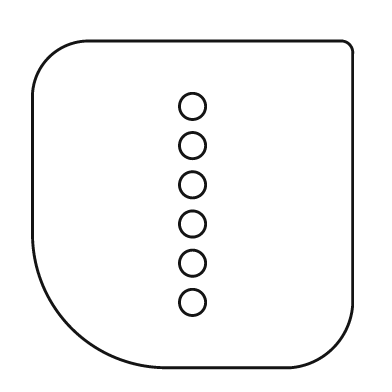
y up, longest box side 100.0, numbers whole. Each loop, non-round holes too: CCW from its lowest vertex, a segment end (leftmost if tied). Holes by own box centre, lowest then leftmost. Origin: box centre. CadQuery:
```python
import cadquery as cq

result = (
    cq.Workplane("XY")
    .moveTo(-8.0, -50.0)
    .lineTo(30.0, -50.0)
    .threePointArc((43.0, -44.0), (49.0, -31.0))
    .lineTo(49.0, 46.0)
    .threePointArc((48.0, 49.0), (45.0, 50.0))
    .lineTo(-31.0, 50.0)
    .threePointArc((-44.0, 45.0), (-49.0, 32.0))
    .lineTo(-49.0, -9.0)
    .threePointArc((-37.0, -38.0), (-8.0, -50.0))
    .close()
    .moveTo(0.0, -30.0)
    .circle(4.0)
    .moveTo(0.0, -18.0)
    .circle(4.0)
    .moveTo(0.0, -6.0)
    .circle(4.0)
    .moveTo(0.0, 6.0)
    .circle(4.0)
    .moveTo(0.0, 18.0)
    .circle(4.0)
    .moveTo(0.0, 30.0)
    .circle(4.0)
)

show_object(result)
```